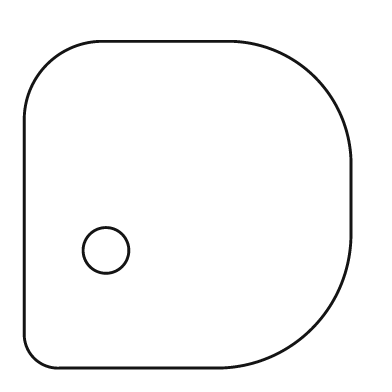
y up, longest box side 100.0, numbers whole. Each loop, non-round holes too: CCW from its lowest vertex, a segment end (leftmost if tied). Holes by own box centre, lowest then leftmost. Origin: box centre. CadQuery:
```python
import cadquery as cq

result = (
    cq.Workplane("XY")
    .moveTo(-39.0, -50.0)
    .lineTo(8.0, -50.0)
    .threePointArc((38.0, -38.0), (50.0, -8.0))
    .lineTo(50.0, 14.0)
    .threePointArc((39.0, 39.0), (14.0, 50.0))
    .lineTo(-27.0, 50.0)
    .threePointArc((-43.0, 43.0), (-50.0, 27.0))
    .lineTo(-50.0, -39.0)
    .threePointArc((-47.0, -47.0), (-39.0, -50.0))
    .close()
    .moveTo(-25.0, -14.0)
    .circle(7.0)
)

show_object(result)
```